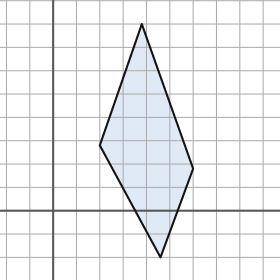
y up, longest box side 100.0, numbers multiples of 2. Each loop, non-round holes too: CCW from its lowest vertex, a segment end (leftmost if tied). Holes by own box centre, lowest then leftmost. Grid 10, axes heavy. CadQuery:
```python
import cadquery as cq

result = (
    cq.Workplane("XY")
    .moveTo(46.0, -20.0)
    .lineTo(60.0, 18.0)
    .lineTo(38.0, 80.0)
    .lineTo(20.0, 28.0)
    .close()
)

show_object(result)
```